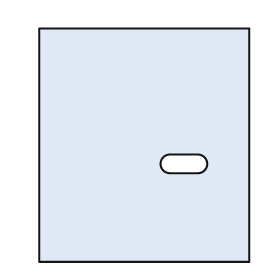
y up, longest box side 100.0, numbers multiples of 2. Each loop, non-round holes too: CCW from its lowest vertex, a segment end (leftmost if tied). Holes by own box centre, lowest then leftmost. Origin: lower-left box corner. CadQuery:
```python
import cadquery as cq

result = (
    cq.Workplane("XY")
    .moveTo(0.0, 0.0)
    .lineTo(90.0, 0.0)
    .lineTo(90.0, 100.0)
    .lineTo(0.0, 100.0)
    .close()
    .moveTo(56.0, 38.0)
    .lineTo(68.0, 38.0)
    .threePointArc((72.0, 42.0), (68.0, 46.0))
    .lineTo(56.0, 46.0)
    .threePointArc((52.0, 42.0), (56.0, 38.0))
    .close()
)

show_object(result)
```